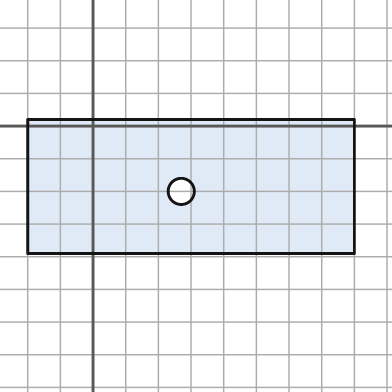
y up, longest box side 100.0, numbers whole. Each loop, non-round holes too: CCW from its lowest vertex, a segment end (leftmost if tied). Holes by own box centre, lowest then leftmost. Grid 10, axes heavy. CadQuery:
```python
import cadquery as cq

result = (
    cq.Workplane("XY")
    .moveTo(-20.0, -39.0)
    .lineTo(80.0, -39.0)
    .lineTo(80.0, 2.0)
    .lineTo(-20.0, 2.0)
    .close()
    .moveTo(27.0, -20.0)
    .circle(4.0)
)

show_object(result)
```